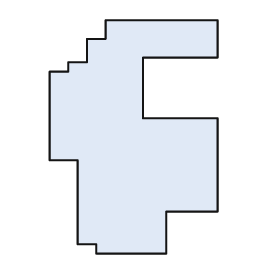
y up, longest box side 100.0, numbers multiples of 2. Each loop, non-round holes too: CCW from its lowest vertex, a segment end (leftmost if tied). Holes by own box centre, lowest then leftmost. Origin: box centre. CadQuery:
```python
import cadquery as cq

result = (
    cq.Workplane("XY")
    .moveTo(-16.0, -50.0)
    .lineTo(14.0, -50.0)
    .lineTo(14.0, -32.0)
    .lineTo(36.0, -32.0)
    .lineTo(36.0, 8.0)
    .lineTo(4.0, 8.0)
    .lineTo(4.0, 34.0)
    .lineTo(36.0, 34.0)
    .lineTo(36.0, 50.0)
    .lineTo(-12.0, 50.0)
    .lineTo(-12.0, 42.0)
    .lineTo(-20.0, 42.0)
    .lineTo(-20.0, 32.0)
    .lineTo(-28.0, 32.0)
    .lineTo(-28.0, 28.0)
    .lineTo(-36.0, 28.0)
    .lineTo(-36.0, -10.0)
    .lineTo(-24.0, -10.0)
    .lineTo(-24.0, -46.0)
    .lineTo(-16.0, -46.0)
    .close()
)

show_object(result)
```